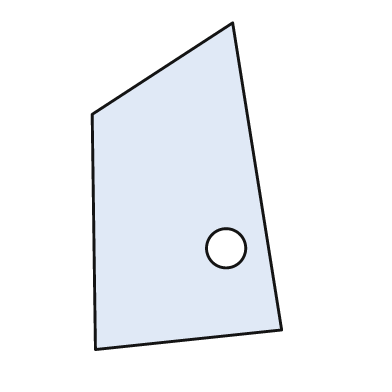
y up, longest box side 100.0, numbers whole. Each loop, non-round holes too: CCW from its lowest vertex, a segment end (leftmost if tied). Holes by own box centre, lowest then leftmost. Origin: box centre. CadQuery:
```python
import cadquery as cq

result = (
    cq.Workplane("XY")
    .moveTo(-28.0, -50.0)
    .lineTo(29.0, -44.0)
    .lineTo(14.0, 50.0)
    .lineTo(-29.0, 22.0)
    .close()
    .moveTo(12.0, -19.0)
    .circle(6.0)
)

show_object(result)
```